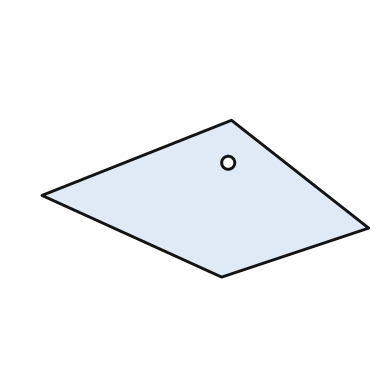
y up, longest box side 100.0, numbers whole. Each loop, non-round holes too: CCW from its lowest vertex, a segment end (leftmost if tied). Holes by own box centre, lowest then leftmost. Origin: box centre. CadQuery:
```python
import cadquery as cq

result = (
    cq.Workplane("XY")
    .moveTo(5.0, -24.0)
    .lineTo(50.0, -9.0)
    .lineTo(8.0, 24.0)
    .lineTo(-50.0, 1.0)
    .close()
    .moveTo(7.0, 11.0)
    .circle(2.0)
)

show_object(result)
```